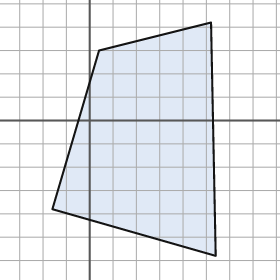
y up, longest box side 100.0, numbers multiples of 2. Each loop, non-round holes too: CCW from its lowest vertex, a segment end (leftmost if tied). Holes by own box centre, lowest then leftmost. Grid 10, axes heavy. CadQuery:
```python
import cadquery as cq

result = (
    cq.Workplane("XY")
    .moveTo(54.0, -58.0)
    .lineTo(52.0, 42.0)
    .lineTo(4.0, 30.0)
    .lineTo(-16.0, -38.0)
    .close()
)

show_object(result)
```